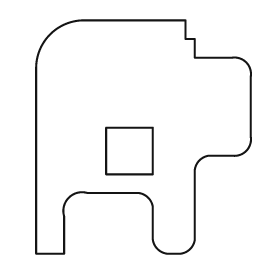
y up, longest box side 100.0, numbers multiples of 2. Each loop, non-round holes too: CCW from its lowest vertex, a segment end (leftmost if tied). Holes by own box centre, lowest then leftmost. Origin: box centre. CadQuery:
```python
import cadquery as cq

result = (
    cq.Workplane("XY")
    .moveTo(-46.0, -50.0)
    .lineTo(-34.0, -50.0)
    .lineTo(-34.0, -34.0)
    .threePointArc((-32.0, -26.0), (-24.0, -24.0))
    .lineTo(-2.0, -24.0)
    .threePointArc((2.0, -26.0), (4.0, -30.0))
    .lineTo(4.0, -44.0)
    .threePointArc((6.0, -48.0), (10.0, -50.0))
    .lineTo(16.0, -50.0)
    .threePointArc((20.0, -48.0), (22.0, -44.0))
    .lineTo(22.0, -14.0)
    .threePointArc((24.0, -10.0), (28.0, -8.0))
    .lineTo(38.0, -8.0)
    .threePointArc((44.0, -6.0), (46.0, 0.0))
    .lineTo(46.0, 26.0)
    .threePointArc((44.0, 32.0), (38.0, 34.0))
    .lineTo(22.0, 34.0)
    .lineTo(22.0, 42.0)
    .lineTo(18.0, 42.0)
    .lineTo(18.0, 50.0)
    .lineTo(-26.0, 50.0)
    .threePointArc((-40.0, 44.0), (-46.0, 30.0))
    .close()
    .moveTo(-16.0, -16.0)
    .lineTo(4.0, -16.0)
    .lineTo(4.0, 4.0)
    .lineTo(-16.0, 4.0)
    .close()
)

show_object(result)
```